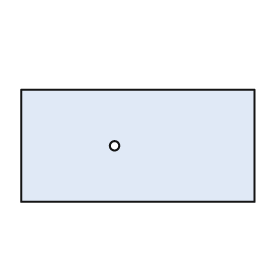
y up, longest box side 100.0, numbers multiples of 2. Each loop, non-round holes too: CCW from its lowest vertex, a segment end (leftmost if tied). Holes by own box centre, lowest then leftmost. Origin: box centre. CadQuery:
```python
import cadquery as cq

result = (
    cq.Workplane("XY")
    .moveTo(-50.0, -24.0)
    .lineTo(50.0, -24.0)
    .lineTo(50.0, 24.0)
    .lineTo(-50.0, 24.0)
    .close()
    .moveTo(-10.0, 0.0)
    .circle(2.0)
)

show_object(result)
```